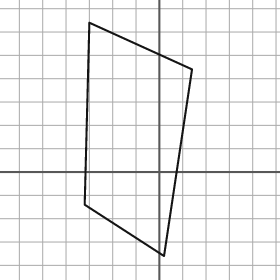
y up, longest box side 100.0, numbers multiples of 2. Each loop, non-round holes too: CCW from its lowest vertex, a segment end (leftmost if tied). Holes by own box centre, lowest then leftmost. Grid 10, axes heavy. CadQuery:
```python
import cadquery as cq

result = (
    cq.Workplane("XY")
    .moveTo(2.0, -36.0)
    .lineTo(14.0, 44.0)
    .lineTo(-30.0, 64.0)
    .lineTo(-32.0, -14.0)
    .close()
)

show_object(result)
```